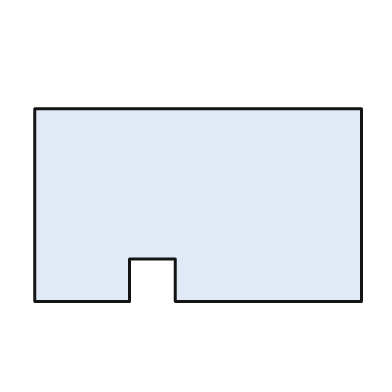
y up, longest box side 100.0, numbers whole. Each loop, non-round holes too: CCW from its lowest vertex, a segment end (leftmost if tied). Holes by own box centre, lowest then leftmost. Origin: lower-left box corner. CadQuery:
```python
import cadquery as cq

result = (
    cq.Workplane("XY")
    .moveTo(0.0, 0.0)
    .lineTo(29.0, 0.0)
    .lineTo(29.0, 13.0)
    .lineTo(43.0, 13.0)
    .lineTo(43.0, 0.0)
    .lineTo(100.0, 0.0)
    .lineTo(100.0, 59.0)
    .lineTo(0.0, 59.0)
    .close()
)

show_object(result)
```